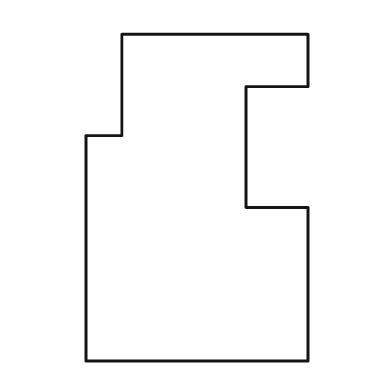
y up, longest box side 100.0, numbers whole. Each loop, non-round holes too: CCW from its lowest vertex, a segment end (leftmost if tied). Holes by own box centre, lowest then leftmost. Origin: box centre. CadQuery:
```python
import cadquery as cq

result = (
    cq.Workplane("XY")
    .moveTo(-34.0, -50.0)
    .lineTo(34.0, -50.0)
    .lineTo(34.0, -3.0)
    .lineTo(15.0, -3.0)
    .lineTo(15.0, 34.0)
    .lineTo(34.0, 34.0)
    .lineTo(34.0, 50.0)
    .lineTo(-23.0, 50.0)
    .lineTo(-23.0, 19.0)
    .lineTo(-34.0, 19.0)
    .close()
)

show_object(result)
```